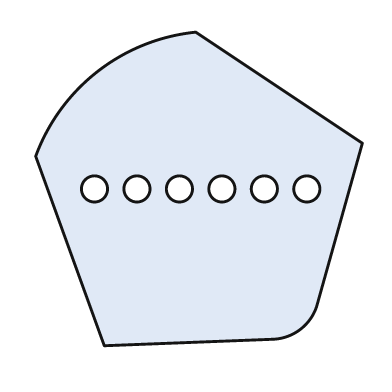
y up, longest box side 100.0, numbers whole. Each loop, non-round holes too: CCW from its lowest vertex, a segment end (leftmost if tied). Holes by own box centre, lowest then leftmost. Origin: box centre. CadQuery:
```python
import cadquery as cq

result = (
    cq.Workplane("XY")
    .moveTo(-29.0, -48.0)
    .lineTo(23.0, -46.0)
    .threePointArc((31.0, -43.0), (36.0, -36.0))
    .lineTo(50.0, 14.0)
    .lineTo(-1.0, 48.0)
    .threePointArc((-31.0, 36.0), (-50.0, 10.0))
    .close()
    .moveTo(-32.0, 0.0)
    .circle(4.0)
    .moveTo(-19.0, 0.0)
    .circle(4.0)
    .moveTo(-6.0, 0.0)
    .circle(4.0)
    .moveTo(7.0, 0.0)
    .circle(4.0)
    .moveTo(20.0, 0.0)
    .circle(4.0)
    .moveTo(33.0, 0.0)
    .circle(4.0)
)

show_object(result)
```